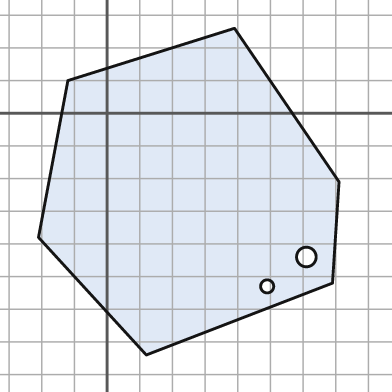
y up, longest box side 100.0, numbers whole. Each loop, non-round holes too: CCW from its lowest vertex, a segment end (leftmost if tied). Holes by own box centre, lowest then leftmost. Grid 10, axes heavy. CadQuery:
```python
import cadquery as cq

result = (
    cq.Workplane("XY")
    .moveTo(12.0, -74.0)
    .lineTo(69.0, -52.0)
    .lineTo(71.0, -21.0)
    .lineTo(39.0, 26.0)
    .lineTo(-12.0, 10.0)
    .lineTo(-21.0, -38.0)
    .close()
    .moveTo(49.0, -53.0)
    .circle(2.0)
    .moveTo(61.0, -44.0)
    .circle(3.0)
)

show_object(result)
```